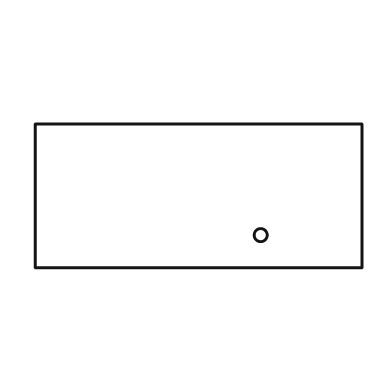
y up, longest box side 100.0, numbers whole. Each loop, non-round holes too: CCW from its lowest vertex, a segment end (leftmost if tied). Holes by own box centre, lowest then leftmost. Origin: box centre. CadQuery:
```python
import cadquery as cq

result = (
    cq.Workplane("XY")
    .moveTo(-50.0, -22.0)
    .lineTo(50.0, -22.0)
    .lineTo(50.0, 22.0)
    .lineTo(-50.0, 22.0)
    .close()
    .moveTo(19.0, -12.0)
    .circle(2.0)
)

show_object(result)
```